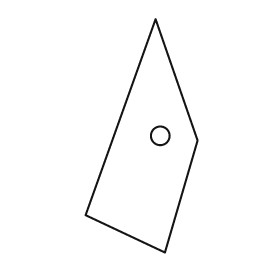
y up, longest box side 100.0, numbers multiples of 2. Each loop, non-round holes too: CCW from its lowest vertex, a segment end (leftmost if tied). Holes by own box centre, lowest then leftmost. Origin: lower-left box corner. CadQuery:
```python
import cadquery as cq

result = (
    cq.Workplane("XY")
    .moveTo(34.0, 0.0)
    .lineTo(48.0, 48.0)
    .lineTo(30.0, 100.0)
    .lineTo(0.0, 16.0)
    .close()
    .moveTo(32.0, 50.0)
    .circle(4.0)
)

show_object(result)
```